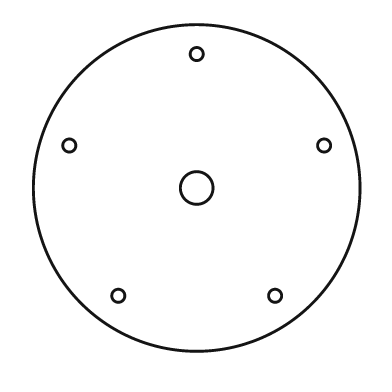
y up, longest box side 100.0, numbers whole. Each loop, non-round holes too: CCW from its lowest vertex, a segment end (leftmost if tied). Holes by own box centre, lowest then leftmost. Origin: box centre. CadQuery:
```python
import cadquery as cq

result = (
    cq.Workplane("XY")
    .moveTo(0.0, 0.0)
    .circle(50.0)
    .moveTo(-24.0, -33.0)
    .circle(2.0)
    .moveTo(24.0, -33.0)
    .circle(2.0)
    .moveTo(0.0, 0.0)
    .circle(5.0)
    .moveTo(-39.0, 13.0)
    .circle(2.0)
    .moveTo(39.0, 13.0)
    .circle(2.0)
    .moveTo(0.0, 41.0)
    .circle(2.0)
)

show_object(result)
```